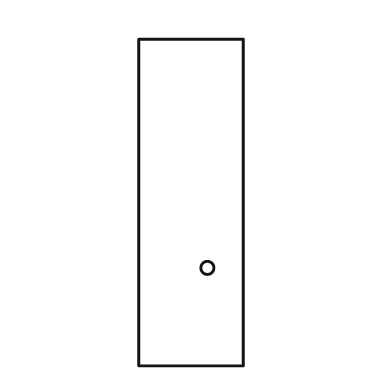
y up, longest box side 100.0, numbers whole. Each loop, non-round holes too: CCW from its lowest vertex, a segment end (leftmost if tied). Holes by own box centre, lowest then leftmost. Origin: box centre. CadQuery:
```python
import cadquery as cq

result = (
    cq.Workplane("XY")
    .moveTo(-16.0, -50.0)
    .lineTo(16.0, -50.0)
    .lineTo(16.0, 50.0)
    .lineTo(-16.0, 50.0)
    .close()
    .moveTo(5.0, -20.0)
    .circle(2.0)
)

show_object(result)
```